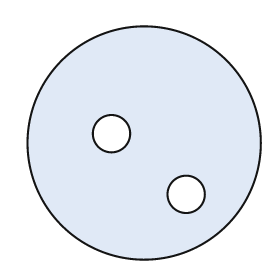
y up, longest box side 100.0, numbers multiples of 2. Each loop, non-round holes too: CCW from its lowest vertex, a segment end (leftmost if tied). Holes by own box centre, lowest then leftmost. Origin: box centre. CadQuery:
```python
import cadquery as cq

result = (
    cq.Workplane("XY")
    .moveTo(0.0, 0.0)
    .circle(50.0)
    .moveTo(18.0, -22.0)
    .circle(8.0)
    .moveTo(-14.0, 4.0)
    .circle(8.0)
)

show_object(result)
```